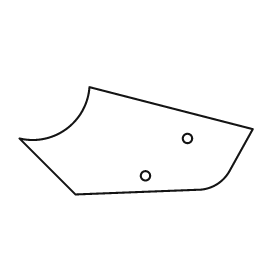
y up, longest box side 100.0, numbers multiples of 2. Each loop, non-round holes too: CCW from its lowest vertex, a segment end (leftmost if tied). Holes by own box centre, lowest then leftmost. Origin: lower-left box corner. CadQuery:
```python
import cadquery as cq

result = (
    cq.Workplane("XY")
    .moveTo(24.0, 0.0)
    .lineTo(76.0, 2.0)
    .threePointArc((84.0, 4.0), (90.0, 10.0))
    .lineTo(100.0, 28.0)
    .lineTo(30.0, 46.0)
    .threePointArc((20.0, 28.0), (0.0, 24.0))
    .close()
    .moveTo(54.0, 8.0)
    .circle(2.0)
    .moveTo(72.0, 24.0)
    .circle(2.0)
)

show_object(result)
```